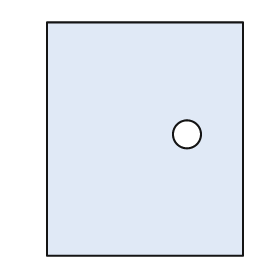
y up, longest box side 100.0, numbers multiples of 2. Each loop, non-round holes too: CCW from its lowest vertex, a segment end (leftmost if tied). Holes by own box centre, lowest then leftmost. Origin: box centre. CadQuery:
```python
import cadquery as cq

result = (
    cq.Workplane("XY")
    .moveTo(-42.0, -50.0)
    .lineTo(42.0, -50.0)
    .lineTo(42.0, 50.0)
    .lineTo(-42.0, 50.0)
    .close()
    .moveTo(18.0, 2.0)
    .circle(6.0)
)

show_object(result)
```